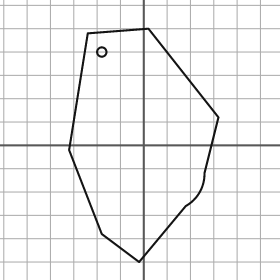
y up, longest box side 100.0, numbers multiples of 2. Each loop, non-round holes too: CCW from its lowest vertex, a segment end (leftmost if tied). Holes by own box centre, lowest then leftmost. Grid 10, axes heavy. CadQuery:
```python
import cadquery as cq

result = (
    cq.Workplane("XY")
    .moveTo(-2.0, -50.0)
    .lineTo(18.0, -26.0)
    .threePointArc((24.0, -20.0), (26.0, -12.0))
    .lineTo(32.0, 12.0)
    .lineTo(2.0, 50.0)
    .lineTo(-24.0, 48.0)
    .lineTo(-32.0, -2.0)
    .lineTo(-18.0, -38.0)
    .close()
    .moveTo(-18.0, 40.0)
    .circle(2.0)
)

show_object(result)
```